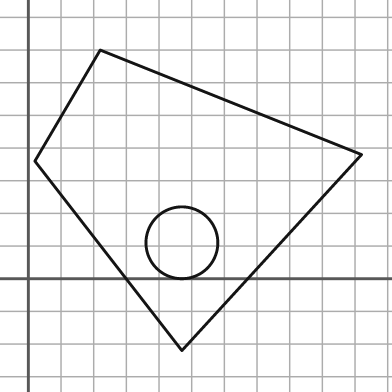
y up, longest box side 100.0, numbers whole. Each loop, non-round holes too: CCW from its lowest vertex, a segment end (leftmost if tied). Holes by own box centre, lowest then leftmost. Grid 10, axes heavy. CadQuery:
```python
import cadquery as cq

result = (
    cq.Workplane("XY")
    .moveTo(47.0, -22.0)
    .lineTo(102.0, 38.0)
    .lineTo(22.0, 70.0)
    .lineTo(2.0, 36.0)
    .close()
    .moveTo(47.0, 11.0)
    .circle(11.0)
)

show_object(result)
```